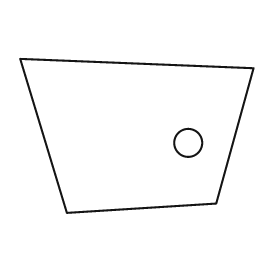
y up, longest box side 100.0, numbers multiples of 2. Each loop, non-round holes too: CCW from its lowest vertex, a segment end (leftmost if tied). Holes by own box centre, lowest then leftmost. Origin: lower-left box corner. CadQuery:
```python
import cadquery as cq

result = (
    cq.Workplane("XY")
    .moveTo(20.0, 0.0)
    .lineTo(84.0, 4.0)
    .lineTo(100.0, 62.0)
    .lineTo(0.0, 66.0)
    .close()
    .moveTo(72.0, 30.0)
    .circle(6.0)
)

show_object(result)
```